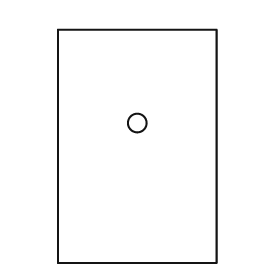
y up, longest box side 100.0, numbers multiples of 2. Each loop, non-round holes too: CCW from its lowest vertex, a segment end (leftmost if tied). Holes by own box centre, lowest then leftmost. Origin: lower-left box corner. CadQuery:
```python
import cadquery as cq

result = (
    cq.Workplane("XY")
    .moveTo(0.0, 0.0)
    .lineTo(68.0, 0.0)
    .lineTo(68.0, 100.0)
    .lineTo(0.0, 100.0)
    .close()
    .moveTo(34.0, 60.0)
    .circle(4.0)
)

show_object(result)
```